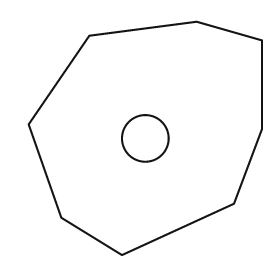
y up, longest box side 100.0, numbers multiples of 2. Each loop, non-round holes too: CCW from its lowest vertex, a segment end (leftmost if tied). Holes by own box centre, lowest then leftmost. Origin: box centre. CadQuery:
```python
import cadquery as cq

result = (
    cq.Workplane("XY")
    .moveTo(-10.0, -50.0)
    .lineTo(38.0, -28.0)
    .lineTo(50.0, 4.0)
    .lineTo(50.0, 42.0)
    .lineTo(22.0, 50.0)
    .lineTo(-24.0, 44.0)
    .lineTo(-50.0, 6.0)
    .lineTo(-36.0, -34.0)
    .close()
    .moveTo(0.0, 0.0)
    .circle(10.0)
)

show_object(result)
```